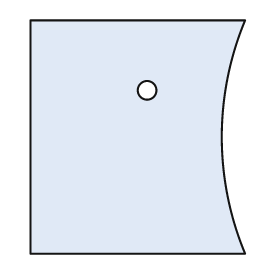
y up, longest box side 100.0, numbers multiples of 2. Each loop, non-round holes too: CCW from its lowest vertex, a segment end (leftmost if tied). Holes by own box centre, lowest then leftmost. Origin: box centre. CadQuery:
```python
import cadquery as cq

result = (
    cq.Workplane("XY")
    .moveTo(-46.0, -50.0)
    .lineTo(46.0, -50.0)
    .threePointArc((36.0, 0.0), (46.0, 50.0))
    .lineTo(-46.0, 50.0)
    .close()
    .moveTo(4.0, 20.0)
    .circle(4.0)
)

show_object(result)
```